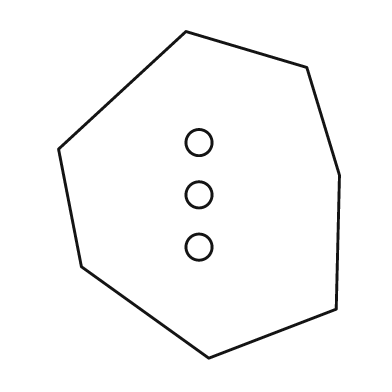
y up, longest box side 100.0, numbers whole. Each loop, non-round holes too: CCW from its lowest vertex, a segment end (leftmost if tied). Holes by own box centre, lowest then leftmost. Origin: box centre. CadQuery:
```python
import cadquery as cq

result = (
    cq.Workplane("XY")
    .moveTo(3.0, -50.0)
    .lineTo(42.0, -35.0)
    .lineTo(43.0, 6.0)
    .lineTo(33.0, 39.0)
    .lineTo(-4.0, 50.0)
    .lineTo(-43.0, 14.0)
    .lineTo(-36.0, -22.0)
    .close()
    .moveTo(0.0, -16.0)
    .circle(4.0)
    .moveTo(0.0, 0.0)
    .circle(4.0)
    .moveTo(0.0, 16.0)
    .circle(4.0)
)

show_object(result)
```